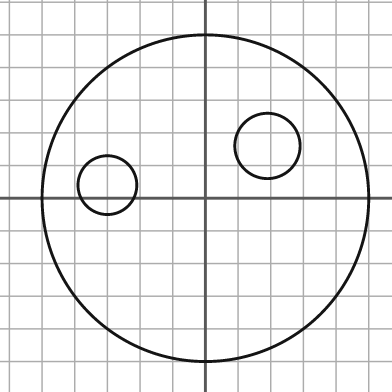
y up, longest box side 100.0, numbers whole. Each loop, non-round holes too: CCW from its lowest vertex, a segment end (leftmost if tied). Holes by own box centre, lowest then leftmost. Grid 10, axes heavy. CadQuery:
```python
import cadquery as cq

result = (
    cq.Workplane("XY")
    .moveTo(0.0, 0.0)
    .circle(50.0)
    .moveTo(-30.0, 4.0)
    .circle(9.0)
    .moveTo(19.0, 16.0)
    .circle(10.0)
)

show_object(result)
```